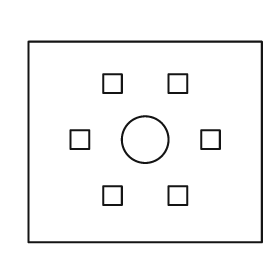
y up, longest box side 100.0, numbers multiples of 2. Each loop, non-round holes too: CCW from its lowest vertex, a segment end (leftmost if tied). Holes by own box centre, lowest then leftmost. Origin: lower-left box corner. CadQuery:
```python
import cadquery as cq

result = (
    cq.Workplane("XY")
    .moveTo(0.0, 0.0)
    .lineTo(100.0, 0.0)
    .lineTo(100.0, 86.0)
    .lineTo(0.0, 86.0)
    .close()
    .moveTo(32.0, 16.0)
    .lineTo(40.0, 16.0)
    .lineTo(40.0, 24.0)
    .lineTo(32.0, 24.0)
    .close()
    .moveTo(60.0, 16.0)
    .lineTo(68.0, 16.0)
    .lineTo(68.0, 24.0)
    .lineTo(60.0, 24.0)
    .close()
    .moveTo(18.0, 40.0)
    .lineTo(26.0, 40.0)
    .lineTo(26.0, 48.0)
    .lineTo(18.0, 48.0)
    .close()
    .moveTo(50.0, 44.0)
    .circle(10.0)
    .moveTo(74.0, 40.0)
    .lineTo(82.0, 40.0)
    .lineTo(82.0, 48.0)
    .lineTo(74.0, 48.0)
    .close()
    .moveTo(32.0, 64.0)
    .lineTo(40.0, 64.0)
    .lineTo(40.0, 72.0)
    .lineTo(32.0, 72.0)
    .close()
    .moveTo(60.0, 64.0)
    .lineTo(68.0, 64.0)
    .lineTo(68.0, 72.0)
    .lineTo(60.0, 72.0)
    .close()
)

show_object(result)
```